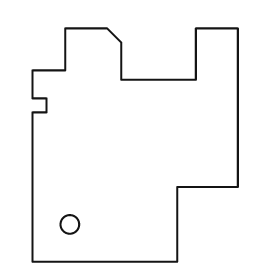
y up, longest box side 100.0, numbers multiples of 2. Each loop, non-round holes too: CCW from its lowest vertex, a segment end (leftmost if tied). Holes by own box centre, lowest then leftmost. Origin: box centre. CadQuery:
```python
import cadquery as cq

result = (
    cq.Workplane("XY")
    .moveTo(-44.0, -50.0)
    .lineTo(18.0, -50.0)
    .lineTo(18.0, -18.0)
    .lineTo(44.0, -18.0)
    .lineTo(44.0, 50.0)
    .lineTo(26.0, 50.0)
    .lineTo(26.0, 28.0)
    .lineTo(-6.0, 28.0)
    .lineTo(-6.0, 44.0)
    .lineTo(-12.0, 50.0)
    .lineTo(-30.0, 50.0)
    .lineTo(-30.0, 32.0)
    .lineTo(-44.0, 32.0)
    .lineTo(-44.0, 20.0)
    .lineTo(-38.0, 20.0)
    .lineTo(-38.0, 14.0)
    .lineTo(-44.0, 14.0)
    .close()
    .moveTo(-28.0, -34.0)
    .circle(4.0)
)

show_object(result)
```